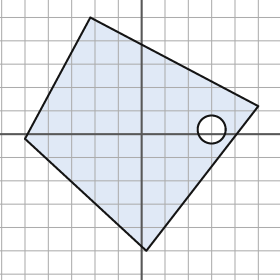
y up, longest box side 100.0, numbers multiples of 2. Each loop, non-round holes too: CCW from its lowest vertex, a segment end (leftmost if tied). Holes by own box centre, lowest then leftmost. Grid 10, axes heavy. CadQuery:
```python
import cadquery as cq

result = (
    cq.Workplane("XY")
    .moveTo(2.0, -50.0)
    .lineTo(50.0, 12.0)
    .lineTo(-22.0, 50.0)
    .lineTo(-50.0, -2.0)
    .close()
    .moveTo(30.0, 2.0)
    .circle(6.0)
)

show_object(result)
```